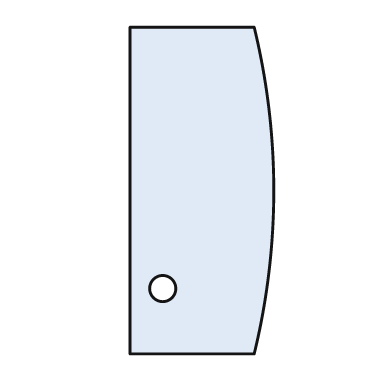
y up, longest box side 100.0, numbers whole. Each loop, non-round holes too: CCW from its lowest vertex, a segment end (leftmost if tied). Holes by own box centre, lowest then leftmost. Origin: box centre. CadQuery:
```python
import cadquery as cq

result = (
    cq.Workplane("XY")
    .moveTo(-22.0, -50.0)
    .lineTo(16.0, -50.0)
    .threePointArc((22.0, 0.0), (16.0, 50.0))
    .lineTo(-22.0, 50.0)
    .close()
    .moveTo(-12.0, -30.0)
    .circle(4.0)
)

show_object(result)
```